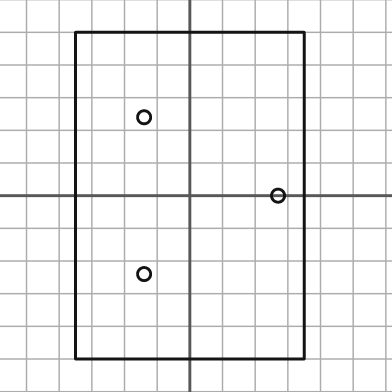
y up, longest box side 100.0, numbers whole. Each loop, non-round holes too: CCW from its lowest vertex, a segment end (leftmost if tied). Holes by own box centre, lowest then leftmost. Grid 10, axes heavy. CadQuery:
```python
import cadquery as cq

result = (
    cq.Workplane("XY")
    .moveTo(-35.0, -50.0)
    .lineTo(35.0, -50.0)
    .lineTo(35.0, 50.0)
    .lineTo(-35.0, 50.0)
    .close()
    .moveTo(-14.0, -24.0)
    .circle(2.0)
    .moveTo(27.0, 0.0)
    .circle(2.0)
    .moveTo(-14.0, 24.0)
    .circle(2.0)
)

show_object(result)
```